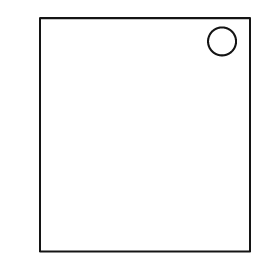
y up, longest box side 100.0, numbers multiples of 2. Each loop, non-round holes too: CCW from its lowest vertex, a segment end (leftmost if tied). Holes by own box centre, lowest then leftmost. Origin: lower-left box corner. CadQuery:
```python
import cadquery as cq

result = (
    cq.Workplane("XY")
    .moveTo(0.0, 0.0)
    .lineTo(90.0, 0.0)
    .lineTo(90.0, 100.0)
    .lineTo(0.0, 100.0)
    .close()
    .moveTo(78.0, 90.0)
    .circle(6.0)
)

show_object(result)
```